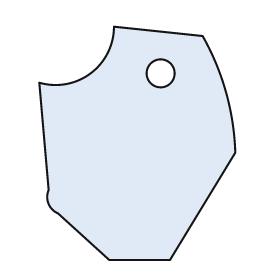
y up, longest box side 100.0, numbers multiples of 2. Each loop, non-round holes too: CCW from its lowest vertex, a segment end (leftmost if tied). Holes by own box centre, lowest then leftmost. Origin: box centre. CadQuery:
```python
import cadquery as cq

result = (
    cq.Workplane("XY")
    .moveTo(-12.0, -50.0)
    .lineTo(14.0, -50.0)
    .lineTo(42.0, -4.0)
    .threePointArc((38.0, 22.0), (28.0, 46.0))
    .lineTo(-10.0, 50.0)
    .threePointArc((-20.0, 30.0), (-42.0, 26.0))
    .lineTo(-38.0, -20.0)
    .threePointArc((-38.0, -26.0), (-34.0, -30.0))
    .close()
    .moveTo(10.0, 30.0)
    .circle(6.0)
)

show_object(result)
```